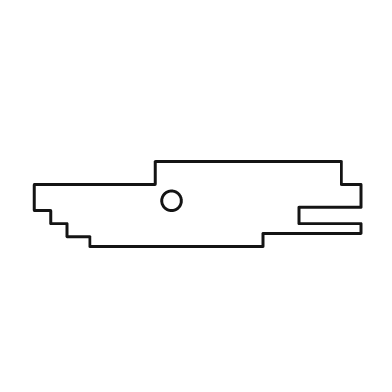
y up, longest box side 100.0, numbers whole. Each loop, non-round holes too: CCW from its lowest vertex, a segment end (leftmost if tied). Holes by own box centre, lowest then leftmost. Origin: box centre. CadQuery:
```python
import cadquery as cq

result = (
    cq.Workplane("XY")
    .moveTo(-33.0, -13.0)
    .lineTo(20.0, -13.0)
    .lineTo(20.0, -9.0)
    .lineTo(50.0, -9.0)
    .lineTo(50.0, -6.0)
    .lineTo(31.0, -6.0)
    .lineTo(31.0, -1.0)
    .lineTo(50.0, -1.0)
    .lineTo(50.0, 6.0)
    .lineTo(44.0, 6.0)
    .lineTo(44.0, 13.0)
    .lineTo(-13.0, 13.0)
    .lineTo(-13.0, 6.0)
    .lineTo(-50.0, 6.0)
    .lineTo(-50.0, -2.0)
    .lineTo(-45.0, -2.0)
    .lineTo(-45.0, -6.0)
    .lineTo(-40.0, -6.0)
    .lineTo(-40.0, -10.0)
    .lineTo(-33.0, -10.0)
    .close()
    .moveTo(-8.0, 1.0)
    .circle(3.0)
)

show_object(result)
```